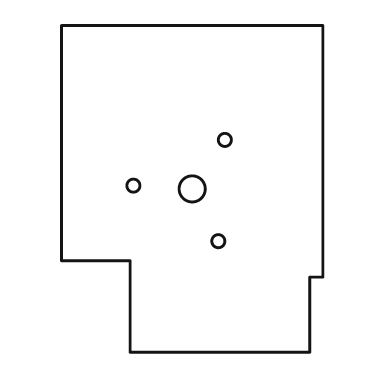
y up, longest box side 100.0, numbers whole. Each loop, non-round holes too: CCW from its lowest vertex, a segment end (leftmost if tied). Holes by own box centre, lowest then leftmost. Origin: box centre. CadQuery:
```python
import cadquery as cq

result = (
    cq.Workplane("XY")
    .moveTo(-19.0, -50.0)
    .lineTo(36.0, -50.0)
    .lineTo(36.0, -27.0)
    .lineTo(40.0, -27.0)
    .lineTo(40.0, 50.0)
    .lineTo(-40.0, 50.0)
    .lineTo(-40.0, -22.0)
    .lineTo(-19.0, -22.0)
    .close()
    .moveTo(8.0, -16.0)
    .circle(2.0)
    .moveTo(0.0, 0.0)
    .circle(4.0)
    .moveTo(-18.0, 1.0)
    .circle(2.0)
    .moveTo(10.0, 15.0)
    .circle(2.0)
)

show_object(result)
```